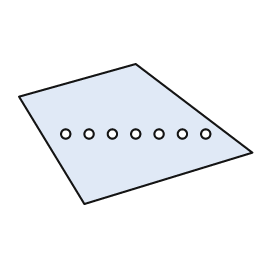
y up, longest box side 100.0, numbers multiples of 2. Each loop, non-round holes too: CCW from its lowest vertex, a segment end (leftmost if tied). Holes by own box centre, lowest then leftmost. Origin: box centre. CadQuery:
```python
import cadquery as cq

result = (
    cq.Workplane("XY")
    .moveTo(-22.0, -30.0)
    .lineTo(50.0, -8.0)
    .lineTo(0.0, 30.0)
    .lineTo(-50.0, 16.0)
    .close()
    .moveTo(-30.0, 0.0)
    .circle(2.0)
    .moveTo(-20.0, 0.0)
    .circle(2.0)
    .moveTo(-10.0, 0.0)
    .circle(2.0)
    .moveTo(0.0, 0.0)
    .circle(2.0)
    .moveTo(10.0, 0.0)
    .circle(2.0)
    .moveTo(20.0, 0.0)
    .circle(2.0)
    .moveTo(30.0, 0.0)
    .circle(2.0)
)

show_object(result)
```